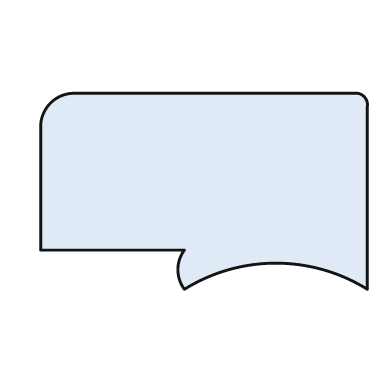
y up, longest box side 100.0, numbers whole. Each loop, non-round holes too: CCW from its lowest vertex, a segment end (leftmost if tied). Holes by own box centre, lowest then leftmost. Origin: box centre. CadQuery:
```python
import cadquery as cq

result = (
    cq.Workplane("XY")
    .moveTo(-6.0, -30.0)
    .threePointArc((22.0, -22.0), (50.0, -30.0))
    .lineTo(50.0, 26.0)
    .threePointArc((49.0, 29.0), (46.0, 30.0))
    .lineTo(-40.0, 30.0)
    .threePointArc((-47.0, 27.0), (-50.0, 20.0))
    .lineTo(-50.0, -18.0)
    .lineTo(-6.0, -18.0)
    .threePointArc((-8.0, -24.0), (-6.0, -30.0))
    .close()
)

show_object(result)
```